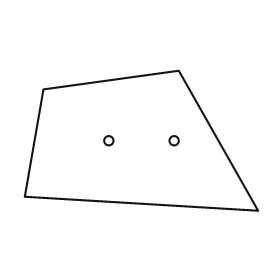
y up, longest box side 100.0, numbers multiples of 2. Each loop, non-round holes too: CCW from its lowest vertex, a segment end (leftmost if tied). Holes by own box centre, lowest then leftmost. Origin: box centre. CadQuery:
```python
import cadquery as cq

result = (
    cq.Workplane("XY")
    .moveTo(50.0, -30.0)
    .lineTo(16.0, 30.0)
    .lineTo(-42.0, 22.0)
    .lineTo(-50.0, -24.0)
    .close()
    .moveTo(-14.0, 0.0)
    .circle(2.0)
    .moveTo(14.0, 0.0)
    .circle(2.0)
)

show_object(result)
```